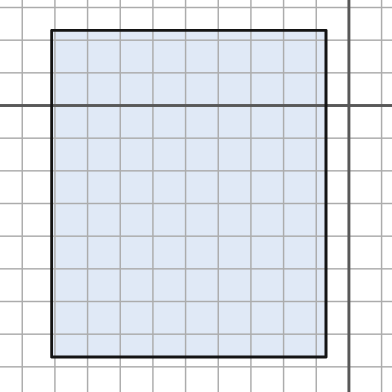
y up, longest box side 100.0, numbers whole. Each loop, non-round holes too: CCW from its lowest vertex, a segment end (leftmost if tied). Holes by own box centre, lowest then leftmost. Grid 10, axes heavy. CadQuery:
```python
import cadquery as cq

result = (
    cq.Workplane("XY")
    .moveTo(-91.0, -77.0)
    .lineTo(-7.0, -77.0)
    .lineTo(-7.0, 23.0)
    .lineTo(-91.0, 23.0)
    .close()
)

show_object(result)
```